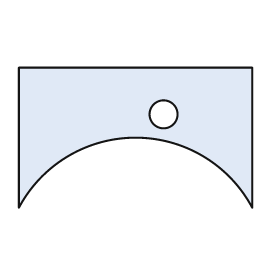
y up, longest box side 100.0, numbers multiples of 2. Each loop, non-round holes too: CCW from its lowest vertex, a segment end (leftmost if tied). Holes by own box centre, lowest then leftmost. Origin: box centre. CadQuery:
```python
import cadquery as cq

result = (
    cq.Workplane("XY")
    .moveTo(-50.0, -30.0)
    .threePointArc((0.0, 0.0), (50.0, -30.0))
    .lineTo(50.0, 30.0)
    .lineTo(-50.0, 30.0)
    .close()
    .moveTo(12.0, 10.0)
    .circle(6.0)
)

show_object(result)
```